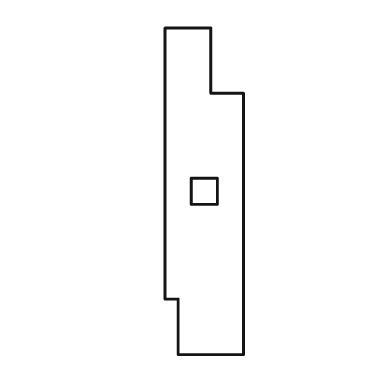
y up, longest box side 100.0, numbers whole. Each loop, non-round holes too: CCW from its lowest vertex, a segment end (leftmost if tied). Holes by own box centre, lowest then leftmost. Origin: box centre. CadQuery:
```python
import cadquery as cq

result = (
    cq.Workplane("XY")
    .moveTo(-8.0, -50.0)
    .lineTo(12.0, -50.0)
    .lineTo(12.0, 30.0)
    .lineTo(2.0, 30.0)
    .lineTo(2.0, 50.0)
    .lineTo(-12.0, 50.0)
    .lineTo(-12.0, -33.0)
    .lineTo(-8.0, -33.0)
    .close()
    .moveTo(-4.0, -4.0)
    .lineTo(4.0, -4.0)
    .lineTo(4.0, 4.0)
    .lineTo(-4.0, 4.0)
    .close()
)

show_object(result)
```